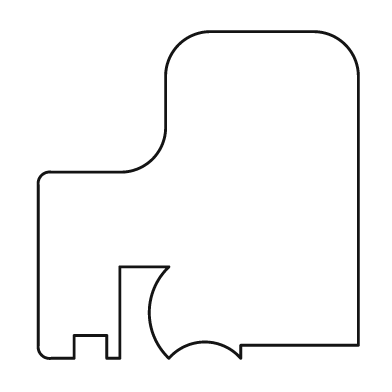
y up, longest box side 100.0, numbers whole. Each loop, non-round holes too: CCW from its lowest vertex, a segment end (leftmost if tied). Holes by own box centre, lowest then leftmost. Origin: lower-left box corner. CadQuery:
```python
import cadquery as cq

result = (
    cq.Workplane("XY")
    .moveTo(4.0, 0.0)
    .lineTo(11.0, 0.0)
    .lineTo(11.0, 7.0)
    .lineTo(21.0, 7.0)
    .lineTo(21.0, 0.0)
    .lineTo(25.0, 0.0)
    .lineTo(25.0, 28.0)
    .lineTo(40.0, 28.0)
    .threePointArc((34.0, 14.0), (40.0, 0.0))
    .threePointArc((51.0, 5.0), (62.0, 0.0))
    .lineTo(62.0, 4.0)
    .lineTo(98.0, 4.0)
    .lineTo(98.0, 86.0)
    .threePointArc((94.0, 96.0), (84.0, 100.0))
    .lineTo(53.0, 100.0)
    .threePointArc((43.0, 96.0), (39.0, 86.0))
    .lineTo(39.0, 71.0)
    .threePointArc((35.0, 61.0), (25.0, 57.0))
    .lineTo(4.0, 57.0)
    .threePointArc((1.0, 56.0), (0.0, 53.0))
    .lineTo(0.0, 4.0)
    .threePointArc((1.0, 1.0), (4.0, 0.0))
    .close()
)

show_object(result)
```